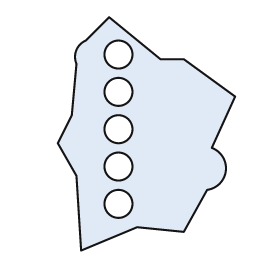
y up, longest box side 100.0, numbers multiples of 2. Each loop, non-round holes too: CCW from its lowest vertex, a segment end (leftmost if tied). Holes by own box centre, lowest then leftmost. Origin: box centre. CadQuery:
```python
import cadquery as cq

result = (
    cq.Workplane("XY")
    .moveTo(-28.0, -50.0)
    .lineTo(-4.0, -40.0)
    .lineTo(16.0, -42.0)
    .lineTo(26.0, -24.0)
    .threePointArc((34.0, -16.0), (28.0, -6.0))
    .lineTo(38.0, 16.0)
    .lineTo(16.0, 32.0)
    .lineTo(6.0, 32.0)
    .lineTo(-16.0, 50.0)
    .lineTo(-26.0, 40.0)
    .threePointArc((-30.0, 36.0), (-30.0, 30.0))
    .lineTo(-32.0, 8.0)
    .lineTo(-38.0, -4.0)
    .lineTo(-30.0, -18.0)
    .close()
    .moveTo(-12.0, -30.0)
    .circle(6.0)
    .moveTo(-12.0, -14.0)
    .circle(6.0)
    .moveTo(-12.0, 2.0)
    .circle(6.0)
    .moveTo(-12.0, 18.0)
    .circle(6.0)
    .moveTo(-12.0, 34.0)
    .circle(6.0)
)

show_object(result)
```